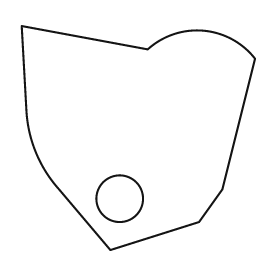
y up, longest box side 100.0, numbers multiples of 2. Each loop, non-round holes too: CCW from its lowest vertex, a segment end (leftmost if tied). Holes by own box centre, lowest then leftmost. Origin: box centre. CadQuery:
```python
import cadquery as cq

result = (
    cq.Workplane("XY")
    .moveTo(-12.0, -48.0)
    .lineTo(26.0, -36.0)
    .lineTo(36.0, -22.0)
    .lineTo(50.0, 34.0)
    .threePointArc((28.0, 46.0), (4.0, 38.0))
    .lineTo(-50.0, 48.0)
    .lineTo(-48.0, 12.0)
    .threePointArc((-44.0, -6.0), (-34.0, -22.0))
    .close()
    .moveTo(-8.0, -26.0)
    .circle(10.0)
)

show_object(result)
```